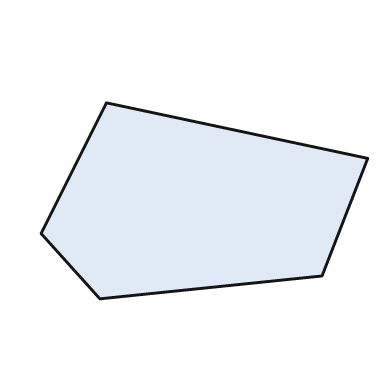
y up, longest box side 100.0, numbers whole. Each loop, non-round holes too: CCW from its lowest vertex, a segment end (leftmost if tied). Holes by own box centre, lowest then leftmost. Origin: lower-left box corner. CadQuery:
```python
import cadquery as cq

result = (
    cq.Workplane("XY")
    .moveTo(18.0, 0.0)
    .lineTo(86.0, 7.0)
    .lineTo(100.0, 43.0)
    .lineTo(20.0, 60.0)
    .lineTo(0.0, 20.0)
    .close()
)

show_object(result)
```